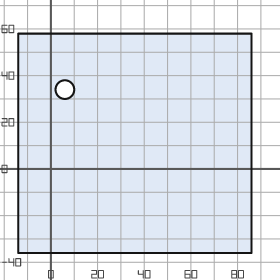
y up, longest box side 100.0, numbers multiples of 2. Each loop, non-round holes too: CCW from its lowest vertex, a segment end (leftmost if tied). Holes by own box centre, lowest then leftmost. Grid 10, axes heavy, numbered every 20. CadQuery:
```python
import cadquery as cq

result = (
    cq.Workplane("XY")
    .moveTo(-14.0, -36.0)
    .lineTo(86.0, -36.0)
    .lineTo(86.0, 58.0)
    .lineTo(-14.0, 58.0)
    .close()
    .moveTo(6.0, 34.0)
    .circle(4.0)
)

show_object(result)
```